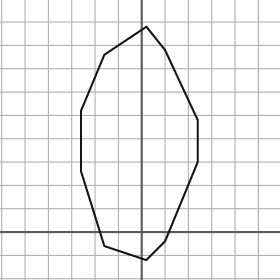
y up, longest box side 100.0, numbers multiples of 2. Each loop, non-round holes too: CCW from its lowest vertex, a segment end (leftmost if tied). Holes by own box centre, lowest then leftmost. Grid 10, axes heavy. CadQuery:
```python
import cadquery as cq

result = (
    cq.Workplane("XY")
    .moveTo(2.0, -12.0)
    .lineTo(10.0, -4.0)
    .lineTo(24.0, 30.0)
    .lineTo(24.0, 48.0)
    .lineTo(10.0, 78.0)
    .lineTo(2.0, 88.0)
    .lineTo(-16.0, 76.0)
    .lineTo(-26.0, 52.0)
    .lineTo(-26.0, 26.0)
    .lineTo(-16.0, -6.0)
    .close()
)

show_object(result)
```